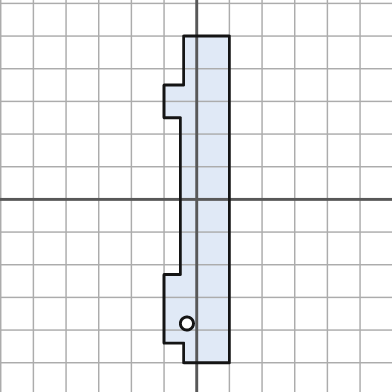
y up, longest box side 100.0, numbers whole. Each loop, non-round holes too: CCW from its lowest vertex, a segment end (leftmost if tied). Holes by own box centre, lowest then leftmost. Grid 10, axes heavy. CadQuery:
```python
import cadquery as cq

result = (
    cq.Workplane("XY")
    .moveTo(-4.0, -50.0)
    .lineTo(10.0, -50.0)
    .lineTo(10.0, 50.0)
    .lineTo(-4.0, 50.0)
    .lineTo(-4.0, 35.0)
    .lineTo(-10.0, 35.0)
    .lineTo(-10.0, 25.0)
    .lineTo(-5.0, 25.0)
    .lineTo(-5.0, -23.0)
    .lineTo(-10.0, -23.0)
    .lineTo(-10.0, -44.0)
    .lineTo(-4.0, -44.0)
    .close()
    .moveTo(-3.0, -38.0)
    .circle(2.0)
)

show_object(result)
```